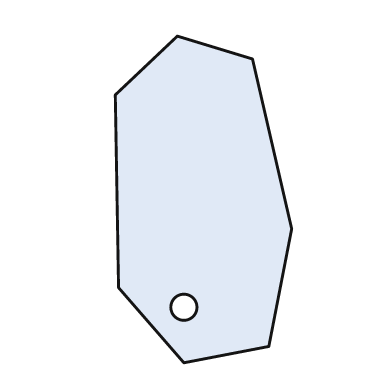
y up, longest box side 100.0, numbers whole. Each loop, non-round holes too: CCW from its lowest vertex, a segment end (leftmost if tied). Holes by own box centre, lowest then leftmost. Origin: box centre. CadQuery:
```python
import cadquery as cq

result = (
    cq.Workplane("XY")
    .moveTo(-6.0, -50.0)
    .lineTo(20.0, -45.0)
    .lineTo(27.0, -9.0)
    .lineTo(15.0, 43.0)
    .lineTo(-8.0, 50.0)
    .lineTo(-27.0, 32.0)
    .lineTo(-26.0, -27.0)
    .close()
    .moveTo(-6.0, -33.0)
    .circle(4.0)
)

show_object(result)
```